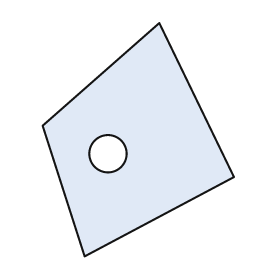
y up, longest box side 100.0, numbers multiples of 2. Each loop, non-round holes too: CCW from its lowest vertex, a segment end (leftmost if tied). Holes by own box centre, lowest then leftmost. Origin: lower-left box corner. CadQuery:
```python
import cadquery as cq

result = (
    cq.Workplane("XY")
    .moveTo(18.0, 0.0)
    .lineTo(82.0, 34.0)
    .lineTo(50.0, 100.0)
    .lineTo(0.0, 56.0)
    .close()
    .moveTo(28.0, 44.0)
    .circle(8.0)
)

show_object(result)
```